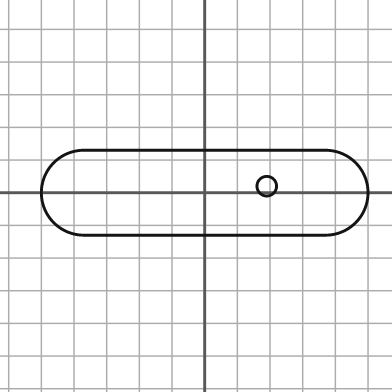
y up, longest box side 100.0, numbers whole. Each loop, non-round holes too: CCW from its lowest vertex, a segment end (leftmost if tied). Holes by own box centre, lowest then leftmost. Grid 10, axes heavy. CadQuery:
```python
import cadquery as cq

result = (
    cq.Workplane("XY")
    .moveTo(-37.0, -13.0)
    .lineTo(37.0, -13.0)
    .threePointArc((50.0, 0.0), (37.0, 13.0))
    .lineTo(-37.0, 13.0)
    .threePointArc((-50.0, 0.0), (-37.0, -13.0))
    .close()
    .moveTo(19.0, 2.0)
    .circle(3.0)
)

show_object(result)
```